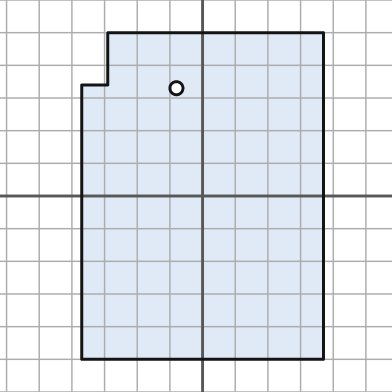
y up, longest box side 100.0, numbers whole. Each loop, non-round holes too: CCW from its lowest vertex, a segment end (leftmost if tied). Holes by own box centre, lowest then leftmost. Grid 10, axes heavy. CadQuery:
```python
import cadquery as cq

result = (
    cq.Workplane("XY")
    .moveTo(-37.0, -50.0)
    .lineTo(37.0, -50.0)
    .lineTo(37.0, 50.0)
    .lineTo(-29.0, 50.0)
    .lineTo(-29.0, 34.0)
    .lineTo(-37.0, 34.0)
    .close()
    .moveTo(-8.0, 33.0)
    .circle(2.0)
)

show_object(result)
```